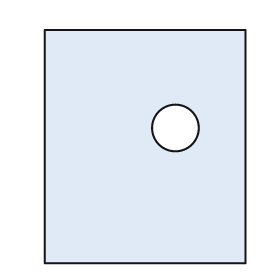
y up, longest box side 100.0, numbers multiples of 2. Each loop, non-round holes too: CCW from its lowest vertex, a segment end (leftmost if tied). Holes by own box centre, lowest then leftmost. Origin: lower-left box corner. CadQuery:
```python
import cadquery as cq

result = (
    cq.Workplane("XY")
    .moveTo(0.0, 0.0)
    .lineTo(86.0, 0.0)
    .lineTo(86.0, 100.0)
    .lineTo(0.0, 100.0)
    .close()
    .moveTo(56.0, 58.0)
    .circle(10.0)
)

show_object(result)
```